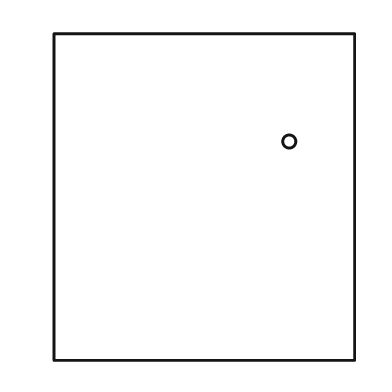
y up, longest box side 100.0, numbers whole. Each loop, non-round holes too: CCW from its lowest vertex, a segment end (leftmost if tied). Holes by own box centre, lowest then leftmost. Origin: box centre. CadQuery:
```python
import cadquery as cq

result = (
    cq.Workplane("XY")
    .moveTo(-46.0, -50.0)
    .lineTo(46.0, -50.0)
    .lineTo(46.0, 50.0)
    .lineTo(-46.0, 50.0)
    .close()
    .moveTo(26.0, 17.0)
    .circle(2.0)
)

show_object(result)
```